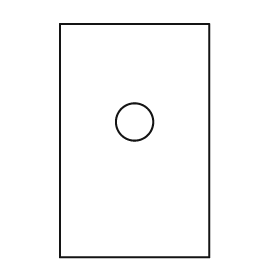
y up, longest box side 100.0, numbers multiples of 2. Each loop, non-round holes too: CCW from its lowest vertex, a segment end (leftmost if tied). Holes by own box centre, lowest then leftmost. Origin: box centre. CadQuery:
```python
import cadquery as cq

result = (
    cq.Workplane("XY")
    .moveTo(-32.0, -50.0)
    .lineTo(32.0, -50.0)
    .lineTo(32.0, 50.0)
    .lineTo(-32.0, 50.0)
    .close()
    .moveTo(0.0, 8.0)
    .circle(8.0)
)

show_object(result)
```